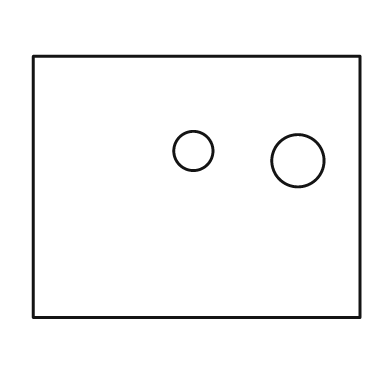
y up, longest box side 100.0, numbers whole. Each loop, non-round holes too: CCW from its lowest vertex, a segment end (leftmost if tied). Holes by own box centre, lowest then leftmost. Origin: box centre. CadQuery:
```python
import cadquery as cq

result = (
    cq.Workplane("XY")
    .moveTo(-50.0, -40.0)
    .lineTo(50.0, -40.0)
    .lineTo(50.0, 40.0)
    .lineTo(-50.0, 40.0)
    .close()
    .moveTo(31.0, 8.0)
    .circle(8.0)
    .moveTo(-1.0, 11.0)
    .circle(6.0)
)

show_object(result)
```